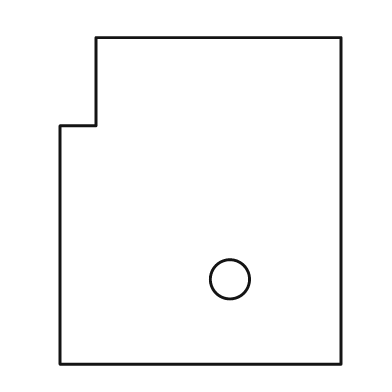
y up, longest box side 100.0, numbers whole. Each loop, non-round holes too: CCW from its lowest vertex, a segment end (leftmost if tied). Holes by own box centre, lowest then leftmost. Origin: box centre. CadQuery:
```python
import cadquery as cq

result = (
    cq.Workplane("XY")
    .moveTo(-43.0, -50.0)
    .lineTo(43.0, -50.0)
    .lineTo(43.0, 50.0)
    .lineTo(-32.0, 50.0)
    .lineTo(-32.0, 23.0)
    .lineTo(-43.0, 23.0)
    .close()
    .moveTo(9.0, -24.0)
    .circle(6.0)
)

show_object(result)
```